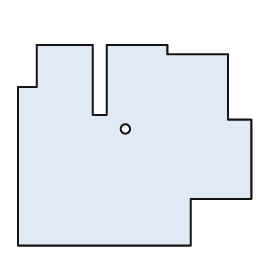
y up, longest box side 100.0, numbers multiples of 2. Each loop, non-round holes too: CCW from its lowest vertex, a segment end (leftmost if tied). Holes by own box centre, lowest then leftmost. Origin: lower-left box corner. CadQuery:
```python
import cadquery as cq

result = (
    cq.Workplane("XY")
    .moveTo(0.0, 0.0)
    .lineTo(74.0, 0.0)
    .lineTo(74.0, 20.0)
    .lineTo(100.0, 20.0)
    .lineTo(100.0, 54.0)
    .lineTo(90.0, 54.0)
    .lineTo(90.0, 82.0)
    .lineTo(64.0, 82.0)
    .lineTo(64.0, 86.0)
    .lineTo(38.0, 86.0)
    .lineTo(38.0, 56.0)
    .lineTo(32.0, 56.0)
    .lineTo(32.0, 86.0)
    .lineTo(8.0, 86.0)
    .lineTo(8.0, 68.0)
    .lineTo(0.0, 68.0)
    .close()
    .moveTo(46.0, 50.0)
    .circle(2.0)
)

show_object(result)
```